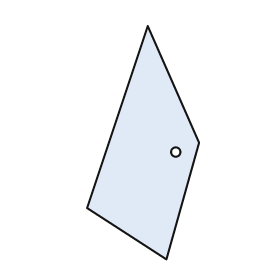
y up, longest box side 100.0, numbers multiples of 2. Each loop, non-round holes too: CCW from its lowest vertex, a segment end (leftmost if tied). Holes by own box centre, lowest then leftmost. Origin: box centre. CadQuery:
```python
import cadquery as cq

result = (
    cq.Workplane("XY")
    .moveTo(10.0, -50.0)
    .lineTo(24.0, 0.0)
    .lineTo(2.0, 50.0)
    .lineTo(-24.0, -28.0)
    .close()
    .moveTo(14.0, -4.0)
    .circle(2.0)
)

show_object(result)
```